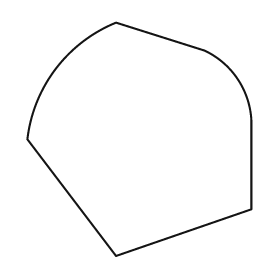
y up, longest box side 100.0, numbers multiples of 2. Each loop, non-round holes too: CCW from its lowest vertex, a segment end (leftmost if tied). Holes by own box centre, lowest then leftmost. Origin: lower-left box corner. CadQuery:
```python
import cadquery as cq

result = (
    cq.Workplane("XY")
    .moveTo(38.0, 0.0)
    .lineTo(96.0, 20.0)
    .lineTo(96.0, 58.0)
    .threePointArc((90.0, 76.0), (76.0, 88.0))
    .lineTo(38.0, 100.0)
    .threePointArc((12.0, 80.0), (0.0, 50.0))
    .close()
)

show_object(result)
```